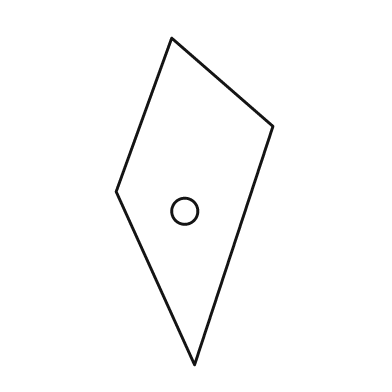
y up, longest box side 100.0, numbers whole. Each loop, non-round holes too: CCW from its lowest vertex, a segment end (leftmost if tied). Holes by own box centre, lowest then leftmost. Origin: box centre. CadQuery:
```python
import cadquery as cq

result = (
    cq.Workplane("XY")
    .moveTo(0.0, -50.0)
    .lineTo(24.0, 23.0)
    .lineTo(-7.0, 50.0)
    .lineTo(-24.0, 3.0)
    .close()
    .moveTo(-3.0, -3.0)
    .circle(4.0)
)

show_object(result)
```